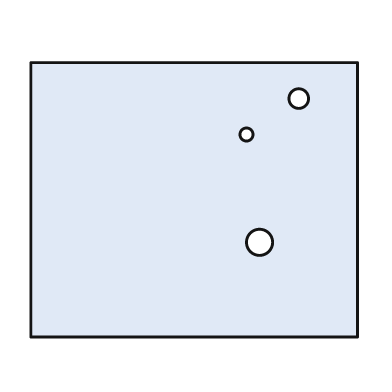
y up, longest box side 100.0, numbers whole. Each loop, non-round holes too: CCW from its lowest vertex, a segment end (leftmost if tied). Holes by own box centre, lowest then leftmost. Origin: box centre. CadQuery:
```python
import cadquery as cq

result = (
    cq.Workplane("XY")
    .moveTo(-50.0, -42.0)
    .lineTo(50.0, -42.0)
    .lineTo(50.0, 42.0)
    .lineTo(-50.0, 42.0)
    .close()
    .moveTo(20.0, -13.0)
    .circle(4.0)
    .moveTo(16.0, 20.0)
    .circle(2.0)
    .moveTo(32.0, 31.0)
    .circle(3.0)
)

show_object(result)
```